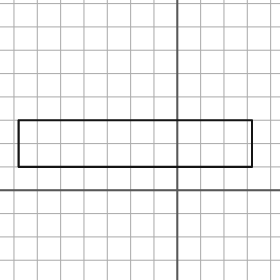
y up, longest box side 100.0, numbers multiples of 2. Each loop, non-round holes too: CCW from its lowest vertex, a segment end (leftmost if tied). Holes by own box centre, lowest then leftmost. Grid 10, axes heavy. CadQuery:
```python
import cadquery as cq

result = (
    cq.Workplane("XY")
    .moveTo(-68.0, 10.0)
    .lineTo(32.0, 10.0)
    .lineTo(32.0, 30.0)
    .lineTo(-68.0, 30.0)
    .close()
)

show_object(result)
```